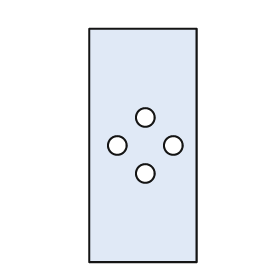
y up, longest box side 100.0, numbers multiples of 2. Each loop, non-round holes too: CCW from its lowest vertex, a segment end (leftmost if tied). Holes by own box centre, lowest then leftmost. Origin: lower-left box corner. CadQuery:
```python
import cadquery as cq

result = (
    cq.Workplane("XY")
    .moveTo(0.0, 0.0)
    .lineTo(46.0, 0.0)
    .lineTo(46.0, 100.0)
    .lineTo(0.0, 100.0)
    .close()
    .moveTo(24.0, 38.0)
    .circle(4.0)
    .moveTo(12.0, 50.0)
    .circle(4.0)
    .moveTo(36.0, 50.0)
    .circle(4.0)
    .moveTo(24.0, 62.0)
    .circle(4.0)
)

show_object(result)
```